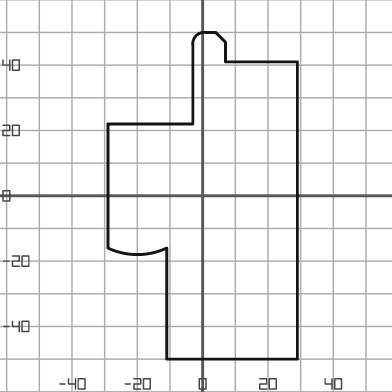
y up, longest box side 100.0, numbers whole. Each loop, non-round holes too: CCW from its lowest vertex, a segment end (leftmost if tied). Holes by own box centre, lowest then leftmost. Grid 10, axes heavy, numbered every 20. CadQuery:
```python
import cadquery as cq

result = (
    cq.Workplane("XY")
    .moveTo(-11.0, -50.0)
    .lineTo(29.0, -50.0)
    .lineTo(29.0, 41.0)
    .lineTo(7.0, 41.0)
    .lineTo(7.0, 47.0)
    .lineTo(4.0, 50.0)
    .lineTo(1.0, 50.0)
    .threePointArc((-2.0, 49.0), (-3.0, 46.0))
    .lineTo(-3.0, 22.0)
    .lineTo(-29.0, 22.0)
    .lineTo(-29.0, -16.0)
    .threePointArc((-20.0, -18.0), (-11.0, -16.0))
    .close()
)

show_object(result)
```